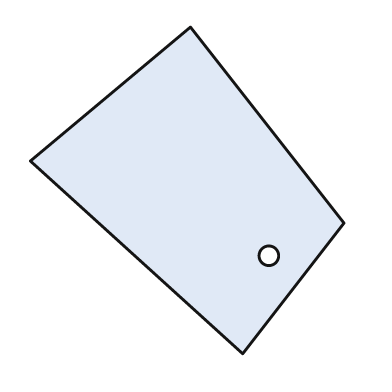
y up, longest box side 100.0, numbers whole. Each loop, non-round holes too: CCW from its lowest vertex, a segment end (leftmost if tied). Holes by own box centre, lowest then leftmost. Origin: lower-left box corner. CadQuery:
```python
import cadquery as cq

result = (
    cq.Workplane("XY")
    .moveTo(65.0, 0.0)
    .lineTo(96.0, 40.0)
    .lineTo(49.0, 100.0)
    .lineTo(0.0, 59.0)
    .close()
    .moveTo(73.0, 30.0)
    .circle(3.0)
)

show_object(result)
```